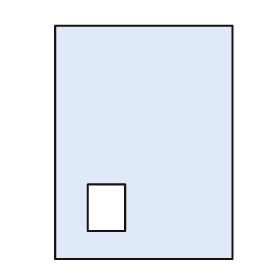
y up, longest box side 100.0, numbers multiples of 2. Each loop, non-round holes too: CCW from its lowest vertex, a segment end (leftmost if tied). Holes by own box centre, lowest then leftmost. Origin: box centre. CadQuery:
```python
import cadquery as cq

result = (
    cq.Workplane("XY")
    .moveTo(-38.0, -50.0)
    .lineTo(38.0, -50.0)
    .lineTo(38.0, 50.0)
    .lineTo(-38.0, 50.0)
    .close()
    .moveTo(-24.0, -38.0)
    .lineTo(-8.0, -38.0)
    .lineTo(-8.0, -18.0)
    .lineTo(-24.0, -18.0)
    .close()
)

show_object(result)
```